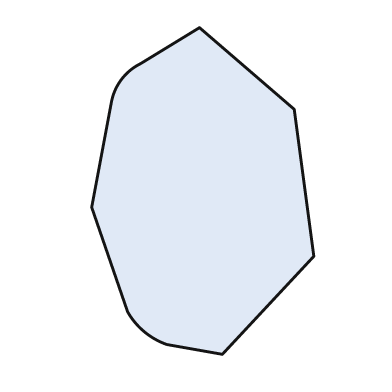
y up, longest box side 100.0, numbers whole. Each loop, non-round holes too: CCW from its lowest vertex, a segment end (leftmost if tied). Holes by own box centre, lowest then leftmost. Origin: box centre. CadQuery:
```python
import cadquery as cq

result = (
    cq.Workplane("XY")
    .moveTo(6.0, -50.0)
    .lineTo(34.0, -20.0)
    .lineTo(28.0, 25.0)
    .lineTo(-1.0, 50.0)
    .lineTo(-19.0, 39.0)
    .threePointArc((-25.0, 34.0), (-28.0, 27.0))
    .lineTo(-34.0, -5.0)
    .lineTo(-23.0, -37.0)
    .threePointArc((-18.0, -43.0), (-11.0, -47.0))
    .close()
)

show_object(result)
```